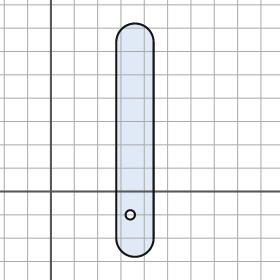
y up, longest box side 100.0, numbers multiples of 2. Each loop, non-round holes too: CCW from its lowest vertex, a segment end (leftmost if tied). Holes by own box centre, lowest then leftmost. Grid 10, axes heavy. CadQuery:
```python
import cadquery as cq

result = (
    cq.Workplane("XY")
    .moveTo(28.0, -20.0)
    .threePointArc((36.0, -28.0), (44.0, -20.0))
    .lineTo(44.0, 64.0)
    .threePointArc((36.0, 72.0), (28.0, 64.0))
    .close()
    .moveTo(34.0, -10.0)
    .circle(2.0)
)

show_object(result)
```